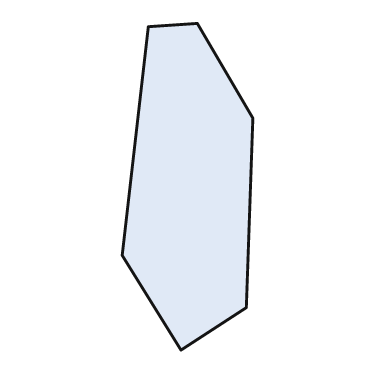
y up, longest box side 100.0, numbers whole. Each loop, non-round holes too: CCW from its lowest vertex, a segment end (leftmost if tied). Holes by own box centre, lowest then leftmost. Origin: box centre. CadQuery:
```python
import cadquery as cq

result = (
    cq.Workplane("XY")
    .moveTo(-2.0, -50.0)
    .lineTo(18.0, -37.0)
    .lineTo(20.0, 21.0)
    .lineTo(3.0, 50.0)
    .lineTo(-12.0, 49.0)
    .lineTo(-20.0, -21.0)
    .close()
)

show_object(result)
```